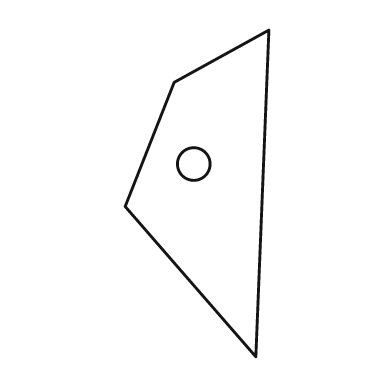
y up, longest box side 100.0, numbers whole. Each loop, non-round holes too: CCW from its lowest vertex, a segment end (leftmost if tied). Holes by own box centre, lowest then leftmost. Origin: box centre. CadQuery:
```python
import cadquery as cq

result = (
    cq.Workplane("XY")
    .moveTo(18.0, -50.0)
    .lineTo(22.0, 50.0)
    .lineTo(-7.0, 34.0)
    .lineTo(-22.0, -4.0)
    .close()
    .moveTo(-1.0, 9.0)
    .circle(5.0)
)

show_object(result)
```